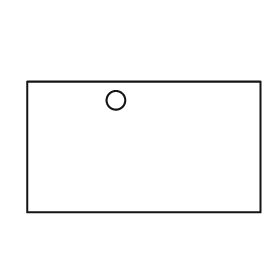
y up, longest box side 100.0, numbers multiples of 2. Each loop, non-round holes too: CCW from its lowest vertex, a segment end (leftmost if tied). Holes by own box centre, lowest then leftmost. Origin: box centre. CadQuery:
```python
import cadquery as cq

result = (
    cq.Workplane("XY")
    .moveTo(-50.0, -28.0)
    .lineTo(50.0, -28.0)
    .lineTo(50.0, 28.0)
    .lineTo(-50.0, 28.0)
    .close()
    .moveTo(-12.0, 20.0)
    .circle(4.0)
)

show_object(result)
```